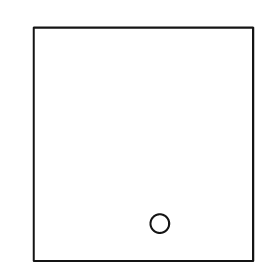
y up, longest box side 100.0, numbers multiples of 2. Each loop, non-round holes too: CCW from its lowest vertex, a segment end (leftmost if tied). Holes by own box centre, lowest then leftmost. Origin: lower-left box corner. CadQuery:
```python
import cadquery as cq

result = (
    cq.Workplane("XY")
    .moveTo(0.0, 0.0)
    .lineTo(94.0, 0.0)
    .lineTo(94.0, 100.0)
    .lineTo(0.0, 100.0)
    .close()
    .moveTo(54.0, 16.0)
    .circle(4.0)
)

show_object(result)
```